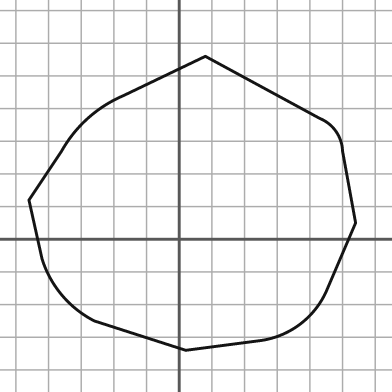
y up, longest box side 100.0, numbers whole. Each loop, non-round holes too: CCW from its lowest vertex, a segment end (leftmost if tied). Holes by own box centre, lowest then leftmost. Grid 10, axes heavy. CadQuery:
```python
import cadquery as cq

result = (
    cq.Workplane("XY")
    .moveTo(2.0, -34.0)
    .lineTo(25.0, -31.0)
    .threePointArc((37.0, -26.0), (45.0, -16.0))
    .lineTo(54.0, 5.0)
    .lineTo(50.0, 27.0)
    .threePointArc((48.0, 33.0), (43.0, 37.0))
    .lineTo(8.0, 56.0)
    .lineTo(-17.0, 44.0)
    .threePointArc((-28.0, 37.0), (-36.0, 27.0))
    .lineTo(-46.0, 12.0)
    .lineTo(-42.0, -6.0)
    .threePointArc((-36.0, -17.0), (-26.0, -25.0))
    .close()
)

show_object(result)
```